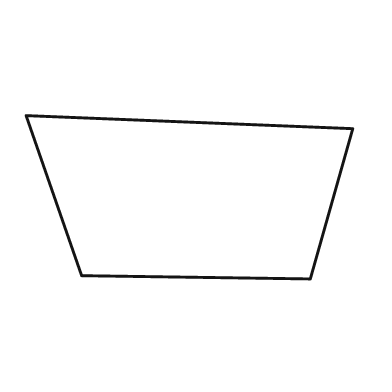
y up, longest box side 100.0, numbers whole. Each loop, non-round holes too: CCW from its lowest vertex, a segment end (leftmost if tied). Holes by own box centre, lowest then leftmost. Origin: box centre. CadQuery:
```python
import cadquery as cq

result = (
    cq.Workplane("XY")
    .moveTo(37.0, -25.0)
    .lineTo(50.0, 21.0)
    .lineTo(-50.0, 25.0)
    .lineTo(-33.0, -24.0)
    .close()
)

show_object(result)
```